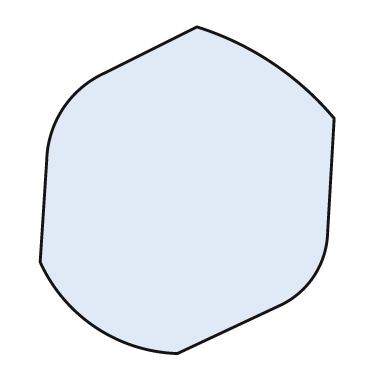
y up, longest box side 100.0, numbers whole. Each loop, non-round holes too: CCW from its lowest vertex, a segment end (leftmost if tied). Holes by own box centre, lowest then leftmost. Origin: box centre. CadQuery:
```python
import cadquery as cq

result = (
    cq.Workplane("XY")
    .moveTo(-3.0, -50.0)
    .lineTo(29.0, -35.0)
    .threePointArc((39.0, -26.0), (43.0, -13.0))
    .lineTo(45.0, 22.0)
    .threePointArc((26.0, 39.0), (3.0, 50.0))
    .lineTo(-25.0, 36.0)
    .threePointArc((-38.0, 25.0), (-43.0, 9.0))
    .lineTo(-45.0, -22.0)
    .threePointArc((-28.0, -42.0), (-3.0, -50.0))
    .close()
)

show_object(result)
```